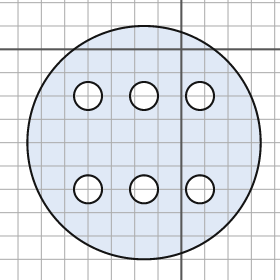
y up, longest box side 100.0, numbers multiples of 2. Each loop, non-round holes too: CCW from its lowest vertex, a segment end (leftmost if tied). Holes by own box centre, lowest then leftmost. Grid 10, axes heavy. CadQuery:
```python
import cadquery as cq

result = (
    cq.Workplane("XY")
    .moveTo(-16.0, -40.0)
    .circle(50.0)
    .moveTo(-40.0, -60.0)
    .circle(6.0)
    .moveTo(-16.0, -60.0)
    .circle(6.0)
    .moveTo(8.0, -60.0)
    .circle(6.0)
    .moveTo(-40.0, -20.0)
    .circle(6.0)
    .moveTo(-16.0, -20.0)
    .circle(6.0)
    .moveTo(8.0, -20.0)
    .circle(6.0)
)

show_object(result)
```